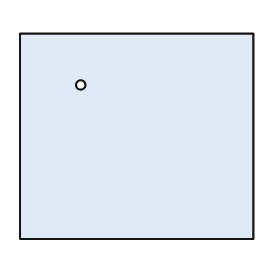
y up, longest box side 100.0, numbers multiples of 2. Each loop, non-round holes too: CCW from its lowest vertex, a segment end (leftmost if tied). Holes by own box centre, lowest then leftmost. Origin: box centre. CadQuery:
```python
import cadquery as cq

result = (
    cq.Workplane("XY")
    .moveTo(-50.0, -44.0)
    .lineTo(50.0, -44.0)
    .lineTo(50.0, 44.0)
    .lineTo(-50.0, 44.0)
    .close()
    .moveTo(-24.0, 22.0)
    .circle(2.0)
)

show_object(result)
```